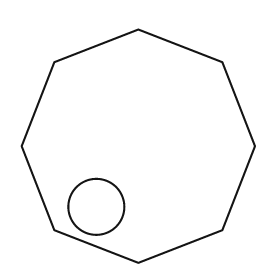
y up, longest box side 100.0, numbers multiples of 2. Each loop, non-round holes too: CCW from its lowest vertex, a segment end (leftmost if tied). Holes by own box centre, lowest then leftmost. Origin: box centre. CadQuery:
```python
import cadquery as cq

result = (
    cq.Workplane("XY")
    .moveTo(0.0, -50.0)
    .lineTo(36.0, -36.0)
    .lineTo(50.0, 0.0)
    .lineTo(36.0, 36.0)
    .lineTo(0.0, 50.0)
    .lineTo(-36.0, 36.0)
    .lineTo(-50.0, 0.0)
    .lineTo(-36.0, -36.0)
    .close()
    .moveTo(-18.0, -26.0)
    .circle(12.0)
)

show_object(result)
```